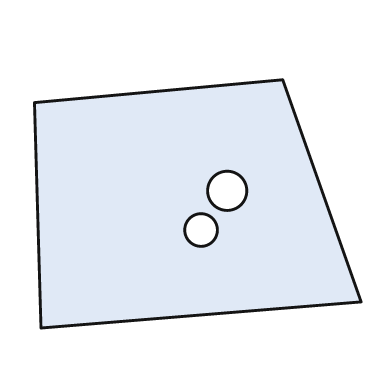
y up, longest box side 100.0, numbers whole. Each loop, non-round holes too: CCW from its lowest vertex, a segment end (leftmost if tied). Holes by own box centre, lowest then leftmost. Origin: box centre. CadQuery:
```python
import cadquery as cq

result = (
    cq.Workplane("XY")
    .moveTo(-48.0, -38.0)
    .lineTo(50.0, -30.0)
    .lineTo(26.0, 38.0)
    .lineTo(-50.0, 31.0)
    .close()
    .moveTo(1.0, -8.0)
    .circle(5.0)
    .moveTo(9.0, 4.0)
    .circle(6.0)
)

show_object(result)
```